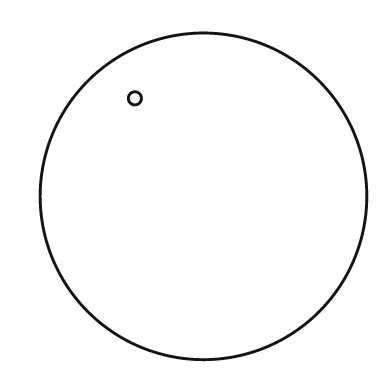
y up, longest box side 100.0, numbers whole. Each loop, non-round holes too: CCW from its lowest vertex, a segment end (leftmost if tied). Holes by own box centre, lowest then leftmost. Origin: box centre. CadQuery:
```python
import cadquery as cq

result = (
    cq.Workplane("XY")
    .moveTo(0.0, 0.0)
    .circle(50.0)
    .moveTo(-21.0, 30.0)
    .circle(2.0)
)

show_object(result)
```